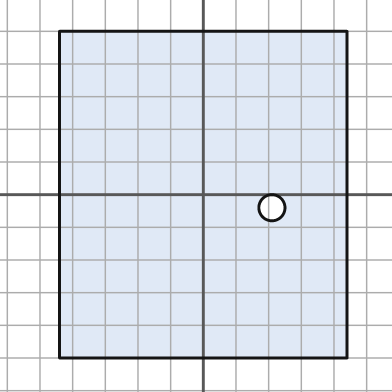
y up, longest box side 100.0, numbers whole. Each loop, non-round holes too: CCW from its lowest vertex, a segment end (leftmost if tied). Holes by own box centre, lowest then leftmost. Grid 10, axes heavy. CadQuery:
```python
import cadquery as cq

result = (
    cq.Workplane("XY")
    .moveTo(-44.0, -50.0)
    .lineTo(44.0, -50.0)
    .lineTo(44.0, 50.0)
    .lineTo(-44.0, 50.0)
    .close()
    .moveTo(21.0, -4.0)
    .circle(4.0)
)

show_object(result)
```